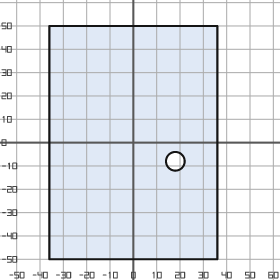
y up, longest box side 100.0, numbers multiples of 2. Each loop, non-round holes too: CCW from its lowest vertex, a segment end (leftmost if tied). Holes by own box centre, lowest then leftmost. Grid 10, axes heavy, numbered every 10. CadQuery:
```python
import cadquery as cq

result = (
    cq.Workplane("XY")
    .moveTo(-36.0, -50.0)
    .lineTo(36.0, -50.0)
    .lineTo(36.0, 50.0)
    .lineTo(-36.0, 50.0)
    .close()
    .moveTo(18.0, -8.0)
    .circle(4.0)
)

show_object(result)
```